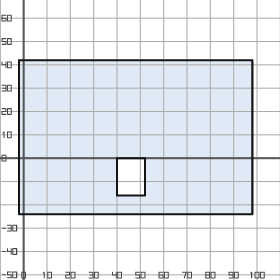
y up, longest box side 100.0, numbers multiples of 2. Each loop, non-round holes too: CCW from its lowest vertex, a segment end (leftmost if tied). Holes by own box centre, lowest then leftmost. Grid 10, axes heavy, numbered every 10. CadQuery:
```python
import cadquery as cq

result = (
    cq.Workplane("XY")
    .moveTo(-2.0, -24.0)
    .lineTo(98.0, -24.0)
    .lineTo(98.0, 42.0)
    .lineTo(-2.0, 42.0)
    .close()
    .moveTo(40.0, -16.0)
    .lineTo(52.0, -16.0)
    .lineTo(52.0, 0.0)
    .lineTo(40.0, 0.0)
    .close()
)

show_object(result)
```